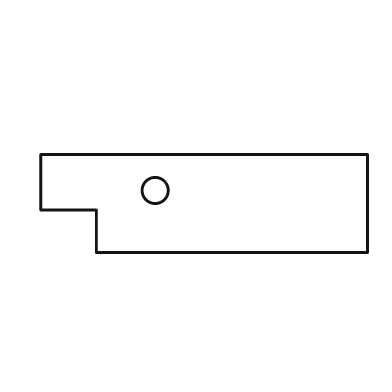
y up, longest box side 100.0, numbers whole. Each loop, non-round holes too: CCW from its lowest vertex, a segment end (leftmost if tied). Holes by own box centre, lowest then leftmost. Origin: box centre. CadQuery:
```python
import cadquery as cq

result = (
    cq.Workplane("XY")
    .moveTo(-33.0, -15.0)
    .lineTo(50.0, -15.0)
    .lineTo(50.0, 15.0)
    .lineTo(-50.0, 15.0)
    .lineTo(-50.0, -2.0)
    .lineTo(-33.0, -2.0)
    .close()
    .moveTo(-15.0, 4.0)
    .circle(4.0)
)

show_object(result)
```